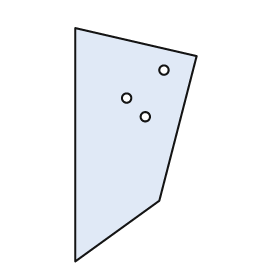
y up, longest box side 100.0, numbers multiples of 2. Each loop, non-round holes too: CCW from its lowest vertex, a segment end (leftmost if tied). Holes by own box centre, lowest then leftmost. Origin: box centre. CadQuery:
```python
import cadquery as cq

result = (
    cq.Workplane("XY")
    .moveTo(-26.0, -50.0)
    .lineTo(10.0, -24.0)
    .lineTo(26.0, 38.0)
    .lineTo(-26.0, 50.0)
    .close()
    .moveTo(4.0, 12.0)
    .circle(2.0)
    .moveTo(-4.0, 20.0)
    .circle(2.0)
    .moveTo(12.0, 32.0)
    .circle(2.0)
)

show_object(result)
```